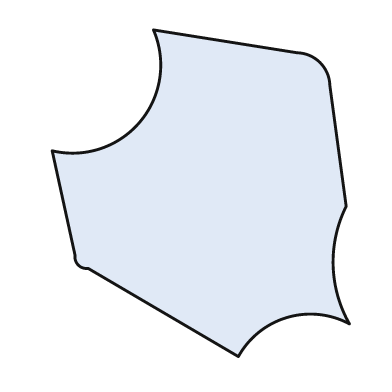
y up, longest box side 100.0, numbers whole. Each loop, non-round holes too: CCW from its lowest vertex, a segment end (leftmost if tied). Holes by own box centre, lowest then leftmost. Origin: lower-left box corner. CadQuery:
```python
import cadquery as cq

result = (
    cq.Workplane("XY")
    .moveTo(57.0, 0.0)
    .threePointArc((72.0, 12.0), (91.0, 10.0))
    .threePointArc((86.0, 28.0), (90.0, 46.0))
    .lineTo(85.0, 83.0)
    .threePointArc((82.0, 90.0), (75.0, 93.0))
    .lineTo(31.0, 100.0)
    .threePointArc((27.0, 72.0), (0.0, 63.0))
    .lineTo(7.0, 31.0)
    .threePointArc((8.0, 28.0), (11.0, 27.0))
    .close()
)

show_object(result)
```